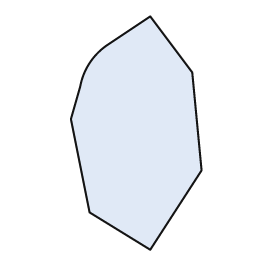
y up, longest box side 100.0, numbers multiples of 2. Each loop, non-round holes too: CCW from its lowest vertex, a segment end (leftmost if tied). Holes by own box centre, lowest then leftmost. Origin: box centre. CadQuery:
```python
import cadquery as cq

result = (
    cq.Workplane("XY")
    .moveTo(6.0, -50.0)
    .lineTo(28.0, -16.0)
    .lineTo(24.0, 26.0)
    .lineTo(6.0, 50.0)
    .lineTo(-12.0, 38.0)
    .threePointArc((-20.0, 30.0), (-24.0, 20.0))
    .lineTo(-28.0, 6.0)
    .lineTo(-20.0, -34.0)
    .close()
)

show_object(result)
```